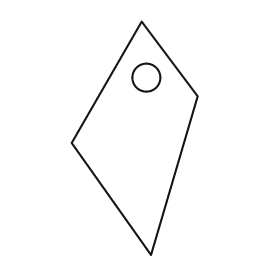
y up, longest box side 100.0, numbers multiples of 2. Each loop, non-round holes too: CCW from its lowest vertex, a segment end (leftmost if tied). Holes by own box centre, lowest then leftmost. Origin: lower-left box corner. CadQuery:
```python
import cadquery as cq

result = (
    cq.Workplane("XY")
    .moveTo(34.0, 0.0)
    .lineTo(54.0, 68.0)
    .lineTo(30.0, 100.0)
    .lineTo(0.0, 48.0)
    .close()
    .moveTo(32.0, 76.0)
    .circle(6.0)
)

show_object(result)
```